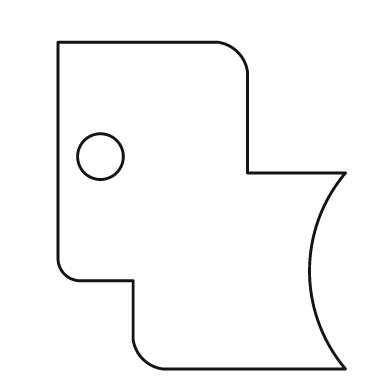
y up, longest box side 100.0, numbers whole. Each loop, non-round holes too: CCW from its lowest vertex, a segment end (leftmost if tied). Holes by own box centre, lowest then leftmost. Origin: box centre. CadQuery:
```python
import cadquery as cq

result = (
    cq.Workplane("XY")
    .moveTo(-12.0, -50.0)
    .lineTo(44.0, -50.0)
    .threePointArc((33.0, -20.0), (44.0, 10.0))
    .lineTo(14.0, 10.0)
    .lineTo(14.0, 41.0)
    .threePointArc((11.0, 47.0), (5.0, 50.0))
    .lineTo(-44.0, 50.0)
    .lineTo(-44.0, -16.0)
    .threePointArc((-42.0, -21.0), (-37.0, -23.0))
    .lineTo(-21.0, -23.0)
    .lineTo(-21.0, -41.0)
    .threePointArc((-18.0, -47.0), (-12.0, -50.0))
    .close()
    .moveTo(-31.0, 15.0)
    .circle(7.0)
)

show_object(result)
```